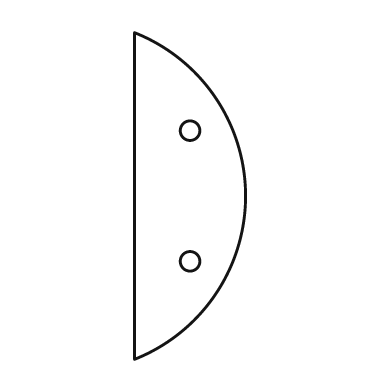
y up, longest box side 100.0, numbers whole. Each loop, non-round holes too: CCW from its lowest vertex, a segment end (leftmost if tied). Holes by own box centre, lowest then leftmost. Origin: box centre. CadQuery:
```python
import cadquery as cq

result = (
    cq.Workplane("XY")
    .moveTo(-17.0, -50.0)
    .threePointArc((17.0, 0.0), (-17.0, 50.0))
    .close()
    .moveTo(0.0, -20.0)
    .circle(3.0)
    .moveTo(0.0, 20.0)
    .circle(3.0)
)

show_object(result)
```